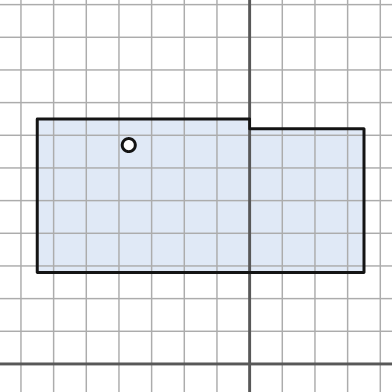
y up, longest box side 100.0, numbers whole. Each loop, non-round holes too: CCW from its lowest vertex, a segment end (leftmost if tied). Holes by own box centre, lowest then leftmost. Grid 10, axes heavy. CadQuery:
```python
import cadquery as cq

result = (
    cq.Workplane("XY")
    .moveTo(-65.0, 28.0)
    .lineTo(35.0, 28.0)
    .lineTo(35.0, 72.0)
    .lineTo(0.0, 72.0)
    .lineTo(0.0, 75.0)
    .lineTo(-65.0, 75.0)
    .close()
    .moveTo(-37.0, 67.0)
    .circle(2.0)
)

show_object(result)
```